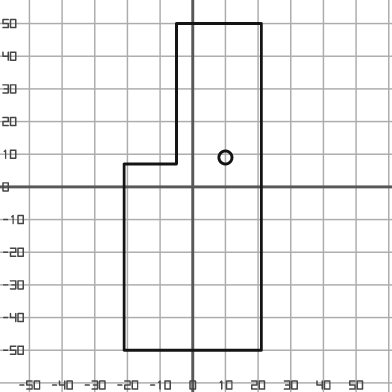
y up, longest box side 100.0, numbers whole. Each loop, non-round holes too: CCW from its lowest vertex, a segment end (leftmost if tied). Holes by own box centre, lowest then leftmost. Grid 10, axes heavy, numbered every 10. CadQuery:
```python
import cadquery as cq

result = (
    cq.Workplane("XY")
    .moveTo(-21.0, -50.0)
    .lineTo(21.0, -50.0)
    .lineTo(21.0, 50.0)
    .lineTo(-5.0, 50.0)
    .lineTo(-5.0, 7.0)
    .lineTo(-21.0, 7.0)
    .close()
    .moveTo(10.0, 9.0)
    .circle(2.0)
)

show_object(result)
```